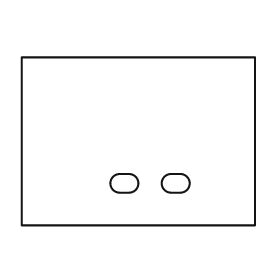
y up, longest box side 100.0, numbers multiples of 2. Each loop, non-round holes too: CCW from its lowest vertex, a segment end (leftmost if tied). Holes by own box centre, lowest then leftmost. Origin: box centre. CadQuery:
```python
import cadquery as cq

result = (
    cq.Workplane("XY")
    .moveTo(-50.0, -36.0)
    .lineTo(50.0, -36.0)
    .lineTo(50.0, 36.0)
    .lineTo(-50.0, 36.0)
    .close()
    .moveTo(-8.0, -22.0)
    .lineTo(-4.0, -22.0)
    .threePointArc((0.0, -18.0), (-4.0, -14.0))
    .lineTo(-8.0, -14.0)
    .threePointArc((-12.0, -18.0), (-8.0, -22.0))
    .close()
    .moveTo(14.0, -22.0)
    .lineTo(18.0, -22.0)
    .threePointArc((22.0, -18.0), (18.0, -14.0))
    .lineTo(14.0, -14.0)
    .threePointArc((10.0, -18.0), (14.0, -22.0))
    .close()
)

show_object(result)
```